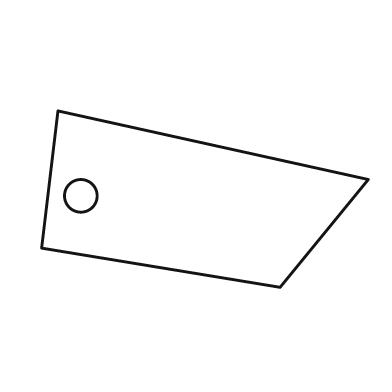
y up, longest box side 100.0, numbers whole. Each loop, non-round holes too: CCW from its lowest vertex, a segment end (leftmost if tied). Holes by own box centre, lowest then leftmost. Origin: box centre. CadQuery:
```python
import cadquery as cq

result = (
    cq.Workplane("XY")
    .moveTo(23.0, -27.0)
    .lineTo(50.0, 6.0)
    .lineTo(-45.0, 27.0)
    .lineTo(-50.0, -15.0)
    .close()
    .moveTo(-38.0, 1.0)
    .circle(5.0)
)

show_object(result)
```